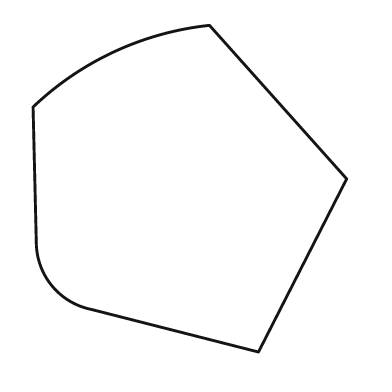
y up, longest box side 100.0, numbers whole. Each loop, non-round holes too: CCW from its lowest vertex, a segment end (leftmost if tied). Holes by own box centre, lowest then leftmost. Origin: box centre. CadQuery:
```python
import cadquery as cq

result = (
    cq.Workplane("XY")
    .moveTo(21.0, -50.0)
    .lineTo(48.0, 3.0)
    .lineTo(6.0, 50.0)
    .threePointArc((-23.0, 42.0), (-48.0, 25.0))
    .lineTo(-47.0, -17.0)
    .threePointArc((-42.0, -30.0), (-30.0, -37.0))
    .close()
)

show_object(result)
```